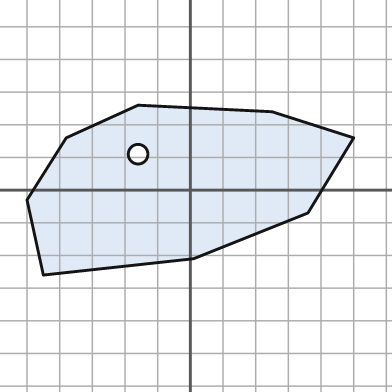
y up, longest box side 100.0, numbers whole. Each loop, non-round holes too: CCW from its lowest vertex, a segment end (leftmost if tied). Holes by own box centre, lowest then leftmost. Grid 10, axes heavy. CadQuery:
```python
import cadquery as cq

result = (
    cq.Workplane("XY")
    .moveTo(-45.0, -26.0)
    .lineTo(1.0, -21.0)
    .lineTo(36.0, -7.0)
    .lineTo(50.0, 16.0)
    .lineTo(25.0, 24.0)
    .lineTo(-16.0, 26.0)
    .lineTo(-38.0, 16.0)
    .lineTo(-50.0, -3.0)
    .close()
    .moveTo(-16.0, 11.0)
    .circle(3.0)
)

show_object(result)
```